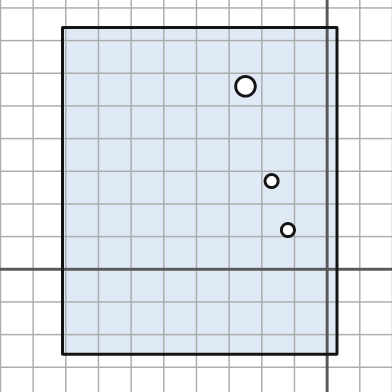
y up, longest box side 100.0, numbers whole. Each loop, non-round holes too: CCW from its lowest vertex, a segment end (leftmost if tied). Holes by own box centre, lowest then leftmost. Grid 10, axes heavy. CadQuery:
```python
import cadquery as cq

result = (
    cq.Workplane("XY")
    .moveTo(-81.0, -26.0)
    .lineTo(3.0, -26.0)
    .lineTo(3.0, 74.0)
    .lineTo(-81.0, 74.0)
    .close()
    .moveTo(-12.0, 12.0)
    .circle(2.0)
    .moveTo(-17.0, 27.0)
    .circle(2.0)
    .moveTo(-25.0, 56.0)
    .circle(3.0)
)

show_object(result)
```